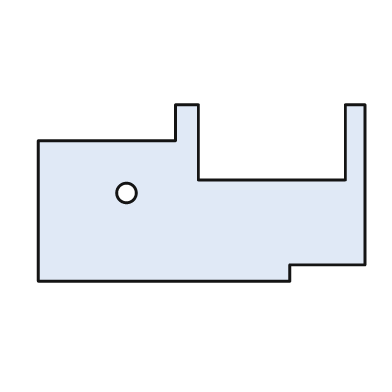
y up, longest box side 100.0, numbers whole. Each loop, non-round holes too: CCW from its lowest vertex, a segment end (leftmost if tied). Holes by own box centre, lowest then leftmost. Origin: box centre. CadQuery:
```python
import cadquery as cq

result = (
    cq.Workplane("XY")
    .moveTo(-50.0, -27.0)
    .lineTo(27.0, -27.0)
    .lineTo(27.0, -22.0)
    .lineTo(50.0, -22.0)
    .lineTo(50.0, 27.0)
    .lineTo(44.0, 27.0)
    .lineTo(44.0, 4.0)
    .lineTo(-1.0, 4.0)
    .lineTo(-1.0, 27.0)
    .lineTo(-8.0, 27.0)
    .lineTo(-8.0, 16.0)
    .lineTo(-50.0, 16.0)
    .close()
    .moveTo(-23.0, 0.0)
    .circle(3.0)
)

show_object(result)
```